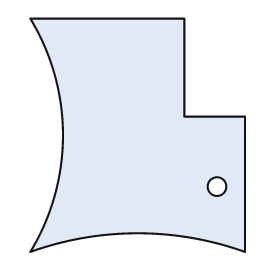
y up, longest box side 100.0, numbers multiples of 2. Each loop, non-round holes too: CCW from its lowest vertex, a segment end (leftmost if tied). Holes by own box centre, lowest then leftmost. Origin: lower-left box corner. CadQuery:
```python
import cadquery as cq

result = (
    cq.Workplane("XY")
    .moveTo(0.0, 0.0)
    .threePointArc((46.0, 8.0), (92.0, 0.0))
    .lineTo(92.0, 58.0)
    .lineTo(66.0, 58.0)
    .lineTo(66.0, 100.0)
    .lineTo(0.0, 100.0)
    .threePointArc((14.0, 50.0), (0.0, 0.0))
    .close()
    .moveTo(80.0, 28.0)
    .circle(4.0)
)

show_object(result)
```